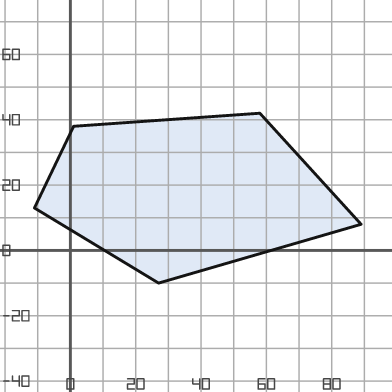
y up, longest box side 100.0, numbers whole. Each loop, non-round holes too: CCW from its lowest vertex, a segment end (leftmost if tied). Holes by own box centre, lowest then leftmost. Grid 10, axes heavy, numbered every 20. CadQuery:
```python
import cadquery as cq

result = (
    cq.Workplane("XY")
    .moveTo(27.0, -10.0)
    .lineTo(89.0, 8.0)
    .lineTo(58.0, 42.0)
    .lineTo(1.0, 38.0)
    .lineTo(-11.0, 13.0)
    .close()
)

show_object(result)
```